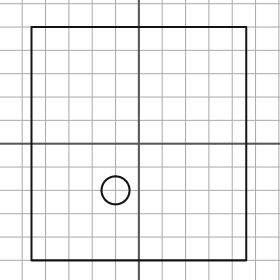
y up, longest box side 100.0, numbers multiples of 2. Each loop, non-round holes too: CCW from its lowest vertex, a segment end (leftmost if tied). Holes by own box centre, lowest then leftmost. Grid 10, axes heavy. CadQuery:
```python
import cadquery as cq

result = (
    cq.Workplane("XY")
    .moveTo(-46.0, -50.0)
    .lineTo(46.0, -50.0)
    .lineTo(46.0, 50.0)
    .lineTo(-46.0, 50.0)
    .close()
    .moveTo(-10.0, -20.0)
    .circle(6.0)
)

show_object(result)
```